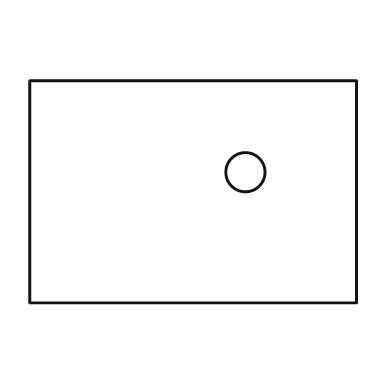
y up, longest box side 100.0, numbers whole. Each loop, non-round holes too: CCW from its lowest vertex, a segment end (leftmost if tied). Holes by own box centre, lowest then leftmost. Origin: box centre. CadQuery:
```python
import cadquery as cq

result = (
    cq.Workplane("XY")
    .moveTo(-50.0, -34.0)
    .lineTo(50.0, -34.0)
    .lineTo(50.0, 34.0)
    .lineTo(-50.0, 34.0)
    .close()
    .moveTo(16.0, 6.0)
    .circle(6.0)
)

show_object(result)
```